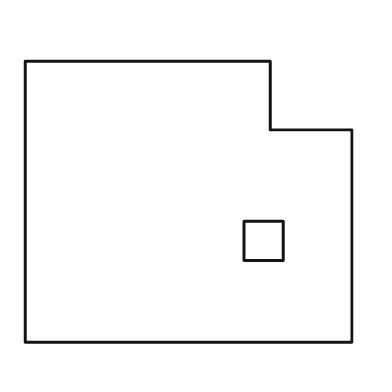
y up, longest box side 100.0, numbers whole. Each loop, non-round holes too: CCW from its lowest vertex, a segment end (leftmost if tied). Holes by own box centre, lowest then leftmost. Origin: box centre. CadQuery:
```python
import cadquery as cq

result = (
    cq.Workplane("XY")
    .moveTo(-50.0, -43.0)
    .lineTo(50.0, -43.0)
    .lineTo(50.0, 22.0)
    .lineTo(25.0, 22.0)
    .lineTo(25.0, 43.0)
    .lineTo(-50.0, 43.0)
    .close()
    .moveTo(17.0, -18.0)
    .lineTo(29.0, -18.0)
    .lineTo(29.0, -6.0)
    .lineTo(17.0, -6.0)
    .close()
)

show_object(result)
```